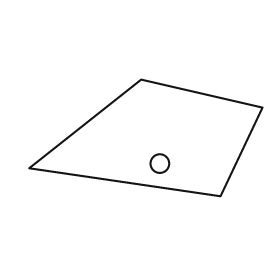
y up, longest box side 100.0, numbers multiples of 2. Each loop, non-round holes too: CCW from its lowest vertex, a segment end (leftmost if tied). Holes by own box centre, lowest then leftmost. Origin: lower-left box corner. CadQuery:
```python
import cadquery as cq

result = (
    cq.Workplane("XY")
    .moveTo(82.0, 0.0)
    .lineTo(100.0, 38.0)
    .lineTo(48.0, 50.0)
    .lineTo(0.0, 12.0)
    .close()
    .moveTo(56.0, 14.0)
    .circle(4.0)
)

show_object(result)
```